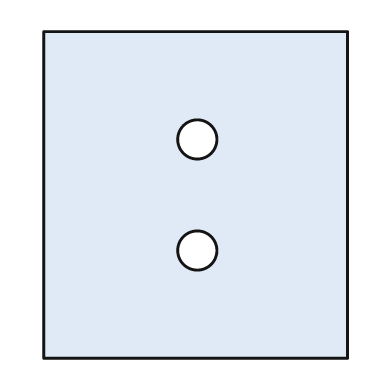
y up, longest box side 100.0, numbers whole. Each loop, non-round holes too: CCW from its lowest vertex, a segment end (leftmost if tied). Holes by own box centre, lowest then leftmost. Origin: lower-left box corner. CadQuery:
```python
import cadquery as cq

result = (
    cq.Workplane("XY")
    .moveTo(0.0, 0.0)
    .lineTo(93.0, 0.0)
    .lineTo(93.0, 100.0)
    .lineTo(0.0, 100.0)
    .close()
    .moveTo(47.0, 33.0)
    .circle(6.0)
    .moveTo(47.0, 67.0)
    .circle(6.0)
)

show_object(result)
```